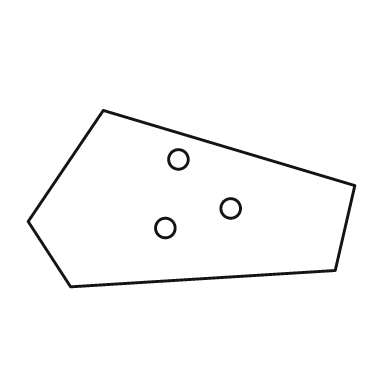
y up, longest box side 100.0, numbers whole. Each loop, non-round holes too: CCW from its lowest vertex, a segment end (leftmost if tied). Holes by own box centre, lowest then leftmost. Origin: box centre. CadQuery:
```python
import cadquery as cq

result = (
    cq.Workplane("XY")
    .moveTo(-37.0, -27.0)
    .lineTo(44.0, -22.0)
    .lineTo(50.0, 4.0)
    .lineTo(-27.0, 27.0)
    .lineTo(-50.0, -7.0)
    .close()
    .moveTo(-8.0, -9.0)
    .circle(3.0)
    .moveTo(12.0, -3.0)
    .circle(3.0)
    .moveTo(-4.0, 12.0)
    .circle(3.0)
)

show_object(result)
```